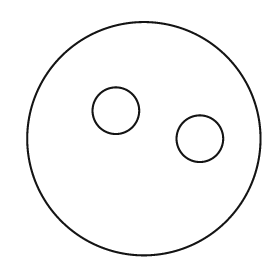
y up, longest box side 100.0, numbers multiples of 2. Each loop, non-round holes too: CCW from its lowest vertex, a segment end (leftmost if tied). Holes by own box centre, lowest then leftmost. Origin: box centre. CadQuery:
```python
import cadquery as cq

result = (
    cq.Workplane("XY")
    .moveTo(0.0, 0.0)
    .circle(50.0)
    .moveTo(24.0, 0.0)
    .circle(10.0)
    .moveTo(-12.0, 12.0)
    .circle(10.0)
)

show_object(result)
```